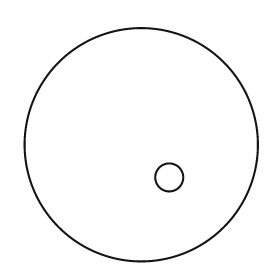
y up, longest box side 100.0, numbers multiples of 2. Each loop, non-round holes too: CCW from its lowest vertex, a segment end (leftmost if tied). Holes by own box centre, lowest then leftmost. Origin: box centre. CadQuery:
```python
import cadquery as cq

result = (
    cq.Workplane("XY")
    .moveTo(0.0, 0.0)
    .circle(50.0)
    .moveTo(12.0, -14.0)
    .circle(6.0)
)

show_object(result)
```